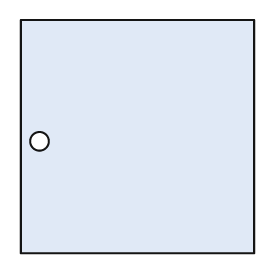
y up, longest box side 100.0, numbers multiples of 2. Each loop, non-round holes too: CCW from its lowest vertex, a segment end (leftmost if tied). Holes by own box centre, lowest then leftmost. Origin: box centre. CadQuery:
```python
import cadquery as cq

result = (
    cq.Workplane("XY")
    .moveTo(-50.0, -50.0)
    .lineTo(50.0, -50.0)
    .lineTo(50.0, 50.0)
    .lineTo(-50.0, 50.0)
    .close()
    .moveTo(-42.0, -2.0)
    .circle(4.0)
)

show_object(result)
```